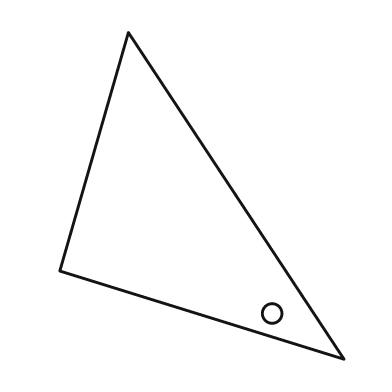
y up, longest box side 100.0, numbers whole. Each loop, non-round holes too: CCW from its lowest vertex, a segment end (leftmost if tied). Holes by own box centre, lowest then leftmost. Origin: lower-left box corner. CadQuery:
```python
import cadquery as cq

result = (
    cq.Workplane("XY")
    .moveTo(87.0, 0.0)
    .lineTo(21.0, 100.0)
    .lineTo(0.0, 27.0)
    .close()
    .moveTo(65.0, 14.0)
    .circle(3.0)
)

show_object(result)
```